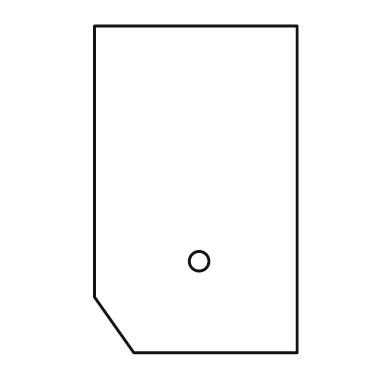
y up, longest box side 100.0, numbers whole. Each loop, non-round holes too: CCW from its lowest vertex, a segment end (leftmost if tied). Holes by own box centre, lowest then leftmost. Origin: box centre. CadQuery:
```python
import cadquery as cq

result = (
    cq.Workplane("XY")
    .moveTo(-19.0, -50.0)
    .lineTo(31.0, -50.0)
    .lineTo(31.0, 50.0)
    .lineTo(-31.0, 50.0)
    .lineTo(-31.0, -33.0)
    .close()
    .moveTo(1.0, -22.0)
    .circle(3.0)
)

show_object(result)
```